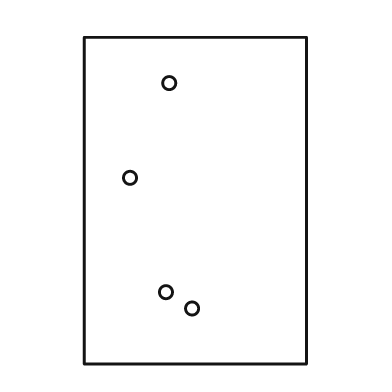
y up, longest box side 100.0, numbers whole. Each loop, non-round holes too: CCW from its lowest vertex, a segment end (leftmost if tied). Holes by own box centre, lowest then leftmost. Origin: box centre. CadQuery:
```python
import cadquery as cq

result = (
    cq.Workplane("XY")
    .moveTo(-34.0, -50.0)
    .lineTo(34.0, -50.0)
    .lineTo(34.0, 50.0)
    .lineTo(-34.0, 50.0)
    .close()
    .moveTo(-1.0, -33.0)
    .circle(2.0)
    .moveTo(-9.0, -28.0)
    .circle(2.0)
    .moveTo(-20.0, 7.0)
    .circle(2.0)
    .moveTo(-8.0, 36.0)
    .circle(2.0)
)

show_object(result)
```